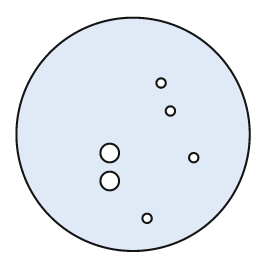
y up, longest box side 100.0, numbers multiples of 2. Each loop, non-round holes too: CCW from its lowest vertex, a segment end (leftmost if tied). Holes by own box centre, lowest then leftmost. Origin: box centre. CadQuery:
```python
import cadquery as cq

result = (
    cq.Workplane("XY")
    .moveTo(0.0, 0.0)
    .circle(50.0)
    .moveTo(6.0, -36.0)
    .circle(2.0)
    .moveTo(-10.0, -20.0)
    .circle(4.0)
    .moveTo(26.0, -10.0)
    .circle(2.0)
    .moveTo(-10.0, -8.0)
    .circle(4.0)
    .moveTo(16.0, 10.0)
    .circle(2.0)
    .moveTo(12.0, 22.0)
    .circle(2.0)
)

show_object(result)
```